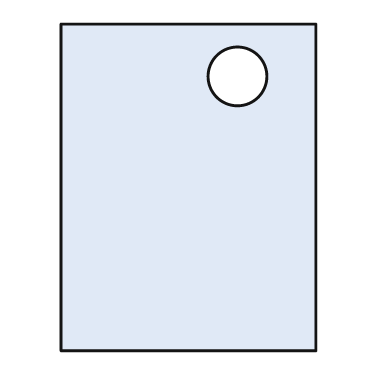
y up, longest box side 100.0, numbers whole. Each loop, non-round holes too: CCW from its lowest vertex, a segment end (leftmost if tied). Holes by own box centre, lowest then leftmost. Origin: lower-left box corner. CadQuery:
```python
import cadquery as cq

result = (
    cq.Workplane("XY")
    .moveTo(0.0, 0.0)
    .lineTo(78.0, 0.0)
    .lineTo(78.0, 100.0)
    .lineTo(0.0, 100.0)
    .close()
    .moveTo(54.0, 84.0)
    .circle(9.0)
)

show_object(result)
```